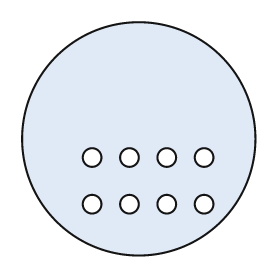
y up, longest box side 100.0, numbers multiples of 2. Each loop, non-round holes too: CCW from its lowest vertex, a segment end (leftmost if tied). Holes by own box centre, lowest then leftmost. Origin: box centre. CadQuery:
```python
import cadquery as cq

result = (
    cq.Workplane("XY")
    .moveTo(0.0, 0.0)
    .circle(50.0)
    .moveTo(-20.0, -28.0)
    .circle(4.0)
    .moveTo(-4.0, -28.0)
    .circle(4.0)
    .moveTo(12.0, -28.0)
    .circle(4.0)
    .moveTo(28.0, -28.0)
    .circle(4.0)
    .moveTo(-20.0, -8.0)
    .circle(4.0)
    .moveTo(-4.0, -8.0)
    .circle(4.0)
    .moveTo(12.0, -8.0)
    .circle(4.0)
    .moveTo(28.0, -8.0)
    .circle(4.0)
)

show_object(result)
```